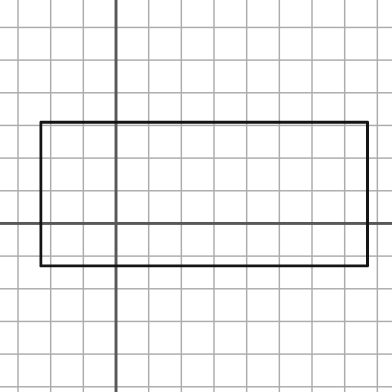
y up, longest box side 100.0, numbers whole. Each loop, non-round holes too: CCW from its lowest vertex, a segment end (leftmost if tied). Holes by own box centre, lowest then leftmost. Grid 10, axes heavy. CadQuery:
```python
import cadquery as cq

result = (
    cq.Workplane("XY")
    .moveTo(-23.0, -13.0)
    .lineTo(77.0, -13.0)
    .lineTo(77.0, 31.0)
    .lineTo(-23.0, 31.0)
    .close()
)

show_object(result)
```